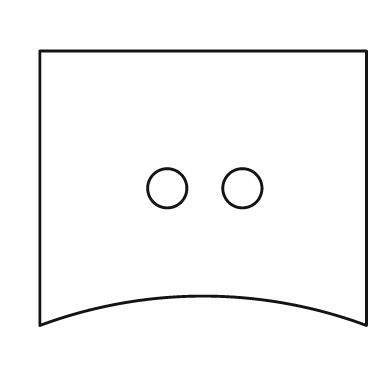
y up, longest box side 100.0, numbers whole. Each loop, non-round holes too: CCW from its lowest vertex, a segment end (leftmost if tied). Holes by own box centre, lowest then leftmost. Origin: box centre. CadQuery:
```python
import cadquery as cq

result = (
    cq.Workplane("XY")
    .moveTo(-50.0, -42.0)
    .threePointArc((0.0, -33.0), (50.0, -42.0))
    .lineTo(50.0, 42.0)
    .lineTo(-50.0, 42.0)
    .close()
    .moveTo(-11.0, 0.0)
    .circle(6.0)
    .moveTo(12.0, 0.0)
    .circle(6.0)
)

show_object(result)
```